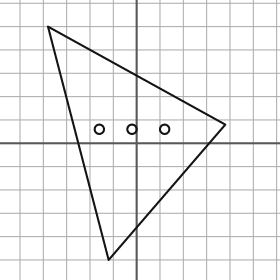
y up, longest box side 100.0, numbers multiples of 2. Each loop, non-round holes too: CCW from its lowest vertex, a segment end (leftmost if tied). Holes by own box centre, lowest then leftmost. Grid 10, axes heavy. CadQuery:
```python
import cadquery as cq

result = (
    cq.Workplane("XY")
    .moveTo(-12.0, -50.0)
    .lineTo(38.0, 8.0)
    .lineTo(-38.0, 50.0)
    .close()
    .moveTo(-16.0, 6.0)
    .circle(2.0)
    .moveTo(-2.0, 6.0)
    .circle(2.0)
    .moveTo(12.0, 6.0)
    .circle(2.0)
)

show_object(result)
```